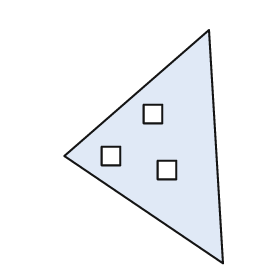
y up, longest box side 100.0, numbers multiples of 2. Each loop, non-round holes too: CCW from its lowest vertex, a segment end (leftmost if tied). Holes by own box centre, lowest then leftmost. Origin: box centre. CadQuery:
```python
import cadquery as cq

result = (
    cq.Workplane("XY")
    .moveTo(34.0, -50.0)
    .lineTo(28.0, 50.0)
    .lineTo(-34.0, -4.0)
    .close()
    .moveTo(6.0, -14.0)
    .lineTo(14.0, -14.0)
    .lineTo(14.0, -6.0)
    .lineTo(6.0, -6.0)
    .close()
    .moveTo(-18.0, -8.0)
    .lineTo(-10.0, -8.0)
    .lineTo(-10.0, 0.0)
    .lineTo(-18.0, 0.0)
    .close()
    .moveTo(0.0, 10.0)
    .lineTo(8.0, 10.0)
    .lineTo(8.0, 18.0)
    .lineTo(0.0, 18.0)
    .close()
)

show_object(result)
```